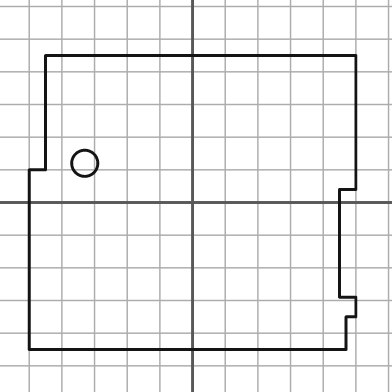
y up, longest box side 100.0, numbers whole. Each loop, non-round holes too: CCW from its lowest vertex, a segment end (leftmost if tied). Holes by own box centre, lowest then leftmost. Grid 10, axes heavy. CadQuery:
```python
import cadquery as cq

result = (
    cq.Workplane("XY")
    .moveTo(-50.0, -45.0)
    .lineTo(47.0, -45.0)
    .lineTo(47.0, -35.0)
    .lineTo(50.0, -35.0)
    .lineTo(50.0, -29.0)
    .lineTo(45.0, -29.0)
    .lineTo(45.0, 4.0)
    .lineTo(50.0, 4.0)
    .lineTo(50.0, 45.0)
    .lineTo(-45.0, 45.0)
    .lineTo(-45.0, 10.0)
    .lineTo(-50.0, 10.0)
    .close()
    .moveTo(-33.0, 12.0)
    .circle(4.0)
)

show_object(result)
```